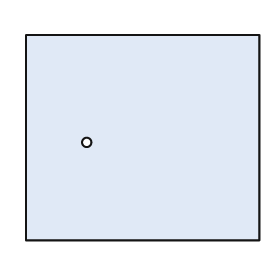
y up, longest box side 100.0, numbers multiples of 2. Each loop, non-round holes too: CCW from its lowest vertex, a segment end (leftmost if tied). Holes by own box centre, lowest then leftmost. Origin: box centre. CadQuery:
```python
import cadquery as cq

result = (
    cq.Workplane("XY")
    .moveTo(-50.0, -44.0)
    .lineTo(50.0, -44.0)
    .lineTo(50.0, 44.0)
    .lineTo(-50.0, 44.0)
    .close()
    .moveTo(-24.0, -2.0)
    .circle(2.0)
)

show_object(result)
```